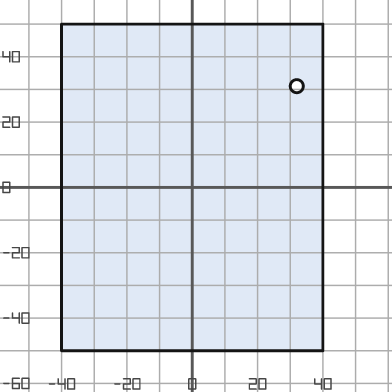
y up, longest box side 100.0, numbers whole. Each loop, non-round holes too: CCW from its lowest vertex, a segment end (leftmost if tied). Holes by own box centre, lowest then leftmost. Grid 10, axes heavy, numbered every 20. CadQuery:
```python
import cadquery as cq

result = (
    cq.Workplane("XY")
    .moveTo(-40.0, -50.0)
    .lineTo(40.0, -50.0)
    .lineTo(40.0, 50.0)
    .lineTo(-40.0, 50.0)
    .close()
    .moveTo(32.0, 31.0)
    .circle(2.0)
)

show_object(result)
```